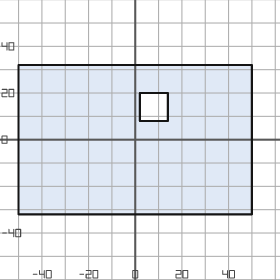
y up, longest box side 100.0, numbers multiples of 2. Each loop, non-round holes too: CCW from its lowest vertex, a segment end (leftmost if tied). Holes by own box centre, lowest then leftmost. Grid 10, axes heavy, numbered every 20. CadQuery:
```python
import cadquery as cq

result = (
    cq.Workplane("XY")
    .moveTo(-50.0, -32.0)
    .lineTo(50.0, -32.0)
    .lineTo(50.0, 32.0)
    .lineTo(-50.0, 32.0)
    .close()
    .moveTo(2.0, 8.0)
    .lineTo(14.0, 8.0)
    .lineTo(14.0, 20.0)
    .lineTo(2.0, 20.0)
    .close()
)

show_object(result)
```